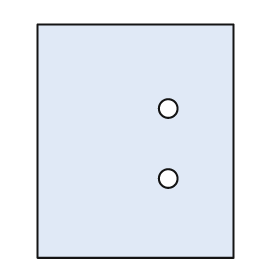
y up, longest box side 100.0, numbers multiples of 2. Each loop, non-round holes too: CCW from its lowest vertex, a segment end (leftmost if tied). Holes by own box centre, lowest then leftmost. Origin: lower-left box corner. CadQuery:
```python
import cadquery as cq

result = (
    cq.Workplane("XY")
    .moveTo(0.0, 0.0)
    .lineTo(84.0, 0.0)
    .lineTo(84.0, 100.0)
    .lineTo(0.0, 100.0)
    .close()
    .moveTo(56.0, 34.0)
    .circle(4.0)
    .moveTo(56.0, 64.0)
    .circle(4.0)
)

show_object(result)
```